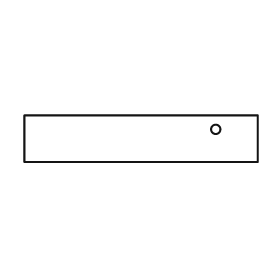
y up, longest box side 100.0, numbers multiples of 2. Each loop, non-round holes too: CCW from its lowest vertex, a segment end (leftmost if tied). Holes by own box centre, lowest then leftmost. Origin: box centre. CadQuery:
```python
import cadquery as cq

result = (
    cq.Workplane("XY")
    .moveTo(-50.0, -10.0)
    .lineTo(50.0, -10.0)
    .lineTo(50.0, 10.0)
    .lineTo(-50.0, 10.0)
    .close()
    .moveTo(32.0, 4.0)
    .circle(2.0)
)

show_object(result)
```